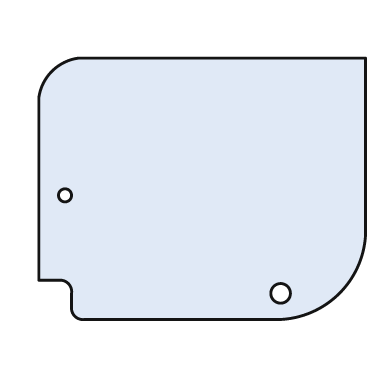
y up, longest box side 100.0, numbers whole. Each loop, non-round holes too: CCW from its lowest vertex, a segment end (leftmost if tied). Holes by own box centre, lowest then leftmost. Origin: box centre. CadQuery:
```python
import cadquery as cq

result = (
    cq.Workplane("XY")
    .moveTo(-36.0, -40.0)
    .lineTo(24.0, -40.0)
    .threePointArc((42.0, -32.0), (50.0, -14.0))
    .lineTo(50.0, 40.0)
    .lineTo(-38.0, 40.0)
    .threePointArc((-46.0, 36.0), (-50.0, 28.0))
    .lineTo(-50.0, -28.0)
    .lineTo(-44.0, -28.0)
    .threePointArc((-41.0, -29.0), (-40.0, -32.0))
    .lineTo(-40.0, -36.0)
    .threePointArc((-39.0, -39.0), (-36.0, -40.0))
    .close()
    .moveTo(24.0, -32.0)
    .circle(3.0)
    .moveTo(-42.0, -2.0)
    .circle(2.0)
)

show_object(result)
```